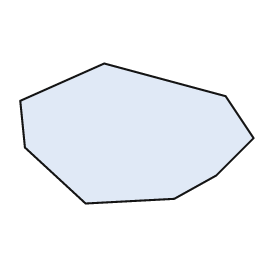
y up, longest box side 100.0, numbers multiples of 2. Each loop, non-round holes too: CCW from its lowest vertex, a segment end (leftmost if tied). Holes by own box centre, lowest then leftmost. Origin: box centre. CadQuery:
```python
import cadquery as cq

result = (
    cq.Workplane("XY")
    .moveTo(-22.0, -30.0)
    .lineTo(16.0, -28.0)
    .lineTo(34.0, -18.0)
    .lineTo(50.0, -2.0)
    .lineTo(38.0, 16.0)
    .lineTo(-14.0, 30.0)
    .lineTo(-50.0, 14.0)
    .lineTo(-48.0, -6.0)
    .close()
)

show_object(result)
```